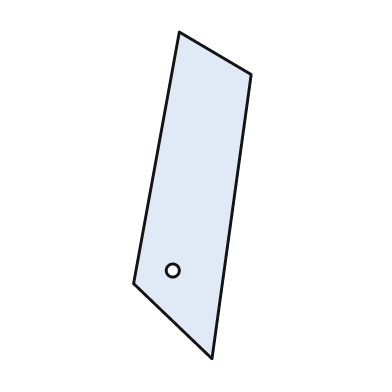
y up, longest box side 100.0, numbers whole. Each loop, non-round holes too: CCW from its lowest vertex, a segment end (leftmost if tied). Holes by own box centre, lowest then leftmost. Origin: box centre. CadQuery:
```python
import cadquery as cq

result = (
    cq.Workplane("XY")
    .moveTo(6.0, -50.0)
    .lineTo(18.0, 37.0)
    .lineTo(-4.0, 50.0)
    .lineTo(-18.0, -27.0)
    .close()
    .moveTo(-6.0, -23.0)
    .circle(2.0)
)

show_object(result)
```